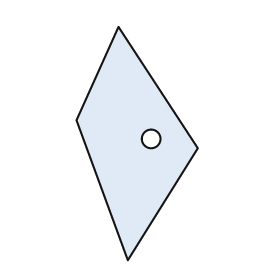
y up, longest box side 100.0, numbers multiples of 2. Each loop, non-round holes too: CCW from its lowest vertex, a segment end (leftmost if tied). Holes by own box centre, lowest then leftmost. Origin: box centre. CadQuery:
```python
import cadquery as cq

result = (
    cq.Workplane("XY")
    .moveTo(-4.0, -50.0)
    .lineTo(26.0, -2.0)
    .lineTo(-8.0, 50.0)
    .lineTo(-26.0, 10.0)
    .close()
    .moveTo(6.0, 2.0)
    .circle(4.0)
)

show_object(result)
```